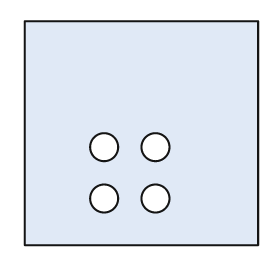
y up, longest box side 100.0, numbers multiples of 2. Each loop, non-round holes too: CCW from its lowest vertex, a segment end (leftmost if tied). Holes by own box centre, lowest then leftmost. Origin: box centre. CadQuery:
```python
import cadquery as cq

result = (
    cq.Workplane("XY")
    .moveTo(-50.0, -48.0)
    .lineTo(50.0, -48.0)
    .lineTo(50.0, 48.0)
    .lineTo(-50.0, 48.0)
    .close()
    .moveTo(-16.0, -28.0)
    .circle(6.0)
    .moveTo(6.0, -28.0)
    .circle(6.0)
    .moveTo(-16.0, -6.0)
    .circle(6.0)
    .moveTo(6.0, -6.0)
    .circle(6.0)
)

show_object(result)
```